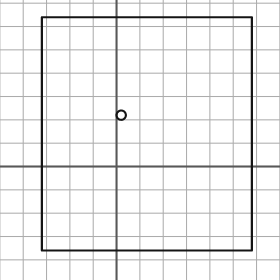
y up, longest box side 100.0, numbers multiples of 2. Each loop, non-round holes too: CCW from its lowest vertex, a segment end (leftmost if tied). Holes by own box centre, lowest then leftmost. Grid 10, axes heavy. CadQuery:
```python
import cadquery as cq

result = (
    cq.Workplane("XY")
    .moveTo(-32.0, -36.0)
    .lineTo(58.0, -36.0)
    .lineTo(58.0, 64.0)
    .lineTo(-32.0, 64.0)
    .close()
    .moveTo(2.0, 22.0)
    .circle(2.0)
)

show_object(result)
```